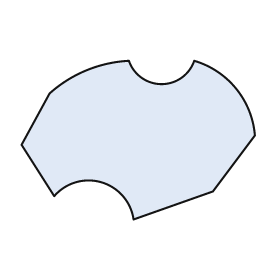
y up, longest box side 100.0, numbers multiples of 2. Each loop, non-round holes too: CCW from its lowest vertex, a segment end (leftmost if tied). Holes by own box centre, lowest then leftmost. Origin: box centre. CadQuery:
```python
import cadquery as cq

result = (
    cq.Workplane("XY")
    .moveTo(-2.0, -34.0)
    .lineTo(32.0, -22.0)
    .lineTo(50.0, 2.0)
    .threePointArc((42.0, 22.0), (24.0, 34.0))
    .threePointArc((10.0, 24.0), (-4.0, 34.0))
    .threePointArc((-22.0, 30.0), (-38.0, 20.0))
    .lineTo(-50.0, -2.0)
    .lineTo(-36.0, -24.0)
    .threePointArc((-16.0, -18.0), (-2.0, -34.0))
    .close()
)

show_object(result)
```